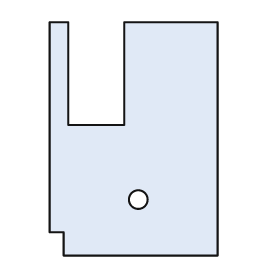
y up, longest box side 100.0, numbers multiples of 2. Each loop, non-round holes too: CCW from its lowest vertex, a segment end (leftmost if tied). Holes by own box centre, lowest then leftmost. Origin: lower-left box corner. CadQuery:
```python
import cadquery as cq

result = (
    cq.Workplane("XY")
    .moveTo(6.0, 0.0)
    .lineTo(72.0, 0.0)
    .lineTo(72.0, 100.0)
    .lineTo(32.0, 100.0)
    .lineTo(32.0, 56.0)
    .lineTo(8.0, 56.0)
    .lineTo(8.0, 100.0)
    .lineTo(0.0, 100.0)
    .lineTo(0.0, 10.0)
    .lineTo(6.0, 10.0)
    .close()
    .moveTo(38.0, 24.0)
    .circle(4.0)
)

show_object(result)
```